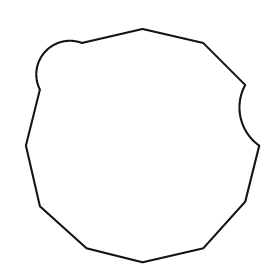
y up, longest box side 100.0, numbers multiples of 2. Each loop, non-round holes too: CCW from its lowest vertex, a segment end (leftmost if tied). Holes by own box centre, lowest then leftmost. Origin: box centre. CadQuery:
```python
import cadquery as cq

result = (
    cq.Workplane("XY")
    .moveTo(0.0, -50.0)
    .lineTo(26.0, -44.0)
    .lineTo(44.0, -24.0)
    .lineTo(50.0, 0.0)
    .threePointArc((42.0, 12.0), (44.0, 26.0))
    .lineTo(26.0, 44.0)
    .lineTo(0.0, 50.0)
    .lineTo(-26.0, 44.0)
    .threePointArc((-42.0, 40.0), (-44.0, 24.0))
    .lineTo(-50.0, 0.0)
    .lineTo(-44.0, -26.0)
    .lineTo(-24.0, -44.0)
    .close()
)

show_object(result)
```